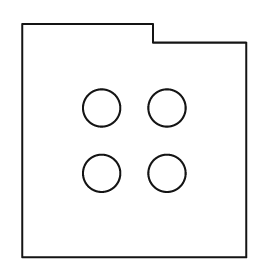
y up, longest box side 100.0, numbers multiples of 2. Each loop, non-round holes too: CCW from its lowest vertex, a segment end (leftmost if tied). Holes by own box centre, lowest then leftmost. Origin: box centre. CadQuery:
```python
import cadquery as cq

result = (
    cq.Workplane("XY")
    .moveTo(-48.0, -50.0)
    .lineTo(48.0, -50.0)
    .lineTo(48.0, 42.0)
    .lineTo(8.0, 42.0)
    .lineTo(8.0, 50.0)
    .lineTo(-48.0, 50.0)
    .close()
    .moveTo(-14.0, -14.0)
    .circle(8.0)
    .moveTo(14.0, -14.0)
    .circle(8.0)
    .moveTo(-14.0, 14.0)
    .circle(8.0)
    .moveTo(14.0, 14.0)
    .circle(8.0)
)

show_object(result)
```